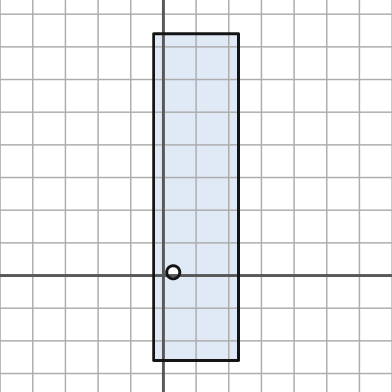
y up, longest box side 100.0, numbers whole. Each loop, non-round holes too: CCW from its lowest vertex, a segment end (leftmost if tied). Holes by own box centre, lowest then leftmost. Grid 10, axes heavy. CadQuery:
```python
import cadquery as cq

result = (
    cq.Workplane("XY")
    .moveTo(-3.0, -26.0)
    .lineTo(23.0, -26.0)
    .lineTo(23.0, 74.0)
    .lineTo(-3.0, 74.0)
    .close()
    .moveTo(3.0, 1.0)
    .circle(2.0)
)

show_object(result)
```